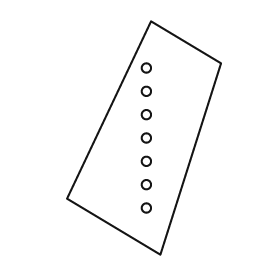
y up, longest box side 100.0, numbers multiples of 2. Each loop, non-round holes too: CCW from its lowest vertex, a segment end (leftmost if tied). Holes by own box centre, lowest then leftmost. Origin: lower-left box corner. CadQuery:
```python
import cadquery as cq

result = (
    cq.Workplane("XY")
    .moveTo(40.0, 0.0)
    .lineTo(66.0, 82.0)
    .lineTo(36.0, 100.0)
    .lineTo(0.0, 24.0)
    .close()
    .moveTo(34.0, 20.0)
    .circle(2.0)
    .moveTo(34.0, 30.0)
    .circle(2.0)
    .moveTo(34.0, 40.0)
    .circle(2.0)
    .moveTo(34.0, 50.0)
    .circle(2.0)
    .moveTo(34.0, 60.0)
    .circle(2.0)
    .moveTo(34.0, 70.0)
    .circle(2.0)
    .moveTo(34.0, 80.0)
    .circle(2.0)
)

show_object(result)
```